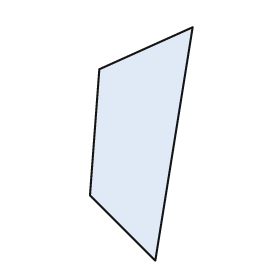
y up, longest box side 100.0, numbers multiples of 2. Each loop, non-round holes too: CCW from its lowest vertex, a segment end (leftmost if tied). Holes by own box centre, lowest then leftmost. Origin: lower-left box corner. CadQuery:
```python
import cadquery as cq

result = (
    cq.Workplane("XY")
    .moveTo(28.0, 0.0)
    .lineTo(44.0, 100.0)
    .lineTo(4.0, 82.0)
    .lineTo(0.0, 28.0)
    .close()
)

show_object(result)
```